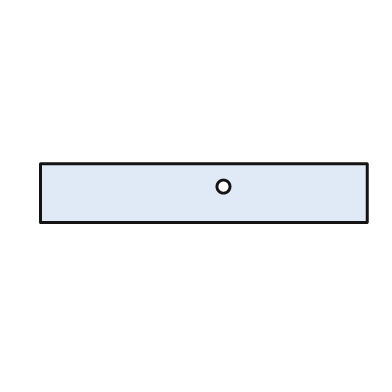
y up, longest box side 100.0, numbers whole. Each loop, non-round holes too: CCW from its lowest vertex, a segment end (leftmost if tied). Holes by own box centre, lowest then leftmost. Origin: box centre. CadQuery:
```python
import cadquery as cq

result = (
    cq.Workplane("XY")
    .moveTo(-50.0, -9.0)
    .lineTo(50.0, -9.0)
    .lineTo(50.0, 9.0)
    .lineTo(-50.0, 9.0)
    .close()
    .moveTo(6.0, 2.0)
    .circle(2.0)
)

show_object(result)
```